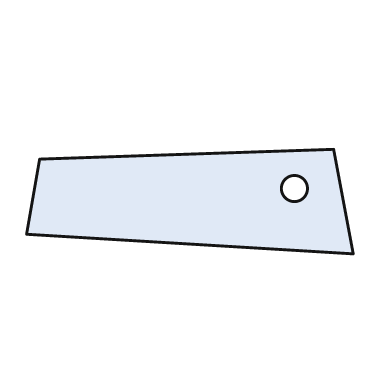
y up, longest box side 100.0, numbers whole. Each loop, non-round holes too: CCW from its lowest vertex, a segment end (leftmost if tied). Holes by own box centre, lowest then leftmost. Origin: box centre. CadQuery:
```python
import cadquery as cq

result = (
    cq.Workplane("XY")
    .moveTo(50.0, -16.0)
    .lineTo(44.0, 16.0)
    .lineTo(-46.0, 13.0)
    .lineTo(-50.0, -10.0)
    .close()
    .moveTo(32.0, 4.0)
    .circle(4.0)
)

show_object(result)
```